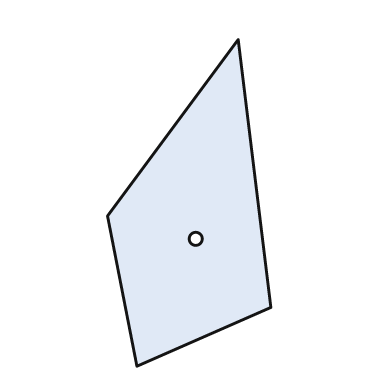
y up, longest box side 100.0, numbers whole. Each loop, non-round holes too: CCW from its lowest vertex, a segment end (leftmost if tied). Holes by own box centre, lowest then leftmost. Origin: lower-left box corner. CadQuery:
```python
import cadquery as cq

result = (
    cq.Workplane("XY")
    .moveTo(9.0, 0.0)
    .lineTo(50.0, 18.0)
    .lineTo(40.0, 100.0)
    .lineTo(0.0, 46.0)
    .close()
    .moveTo(27.0, 39.0)
    .circle(2.0)
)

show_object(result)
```